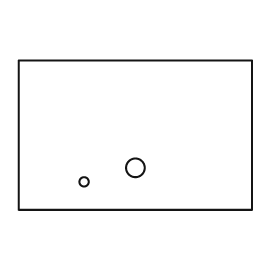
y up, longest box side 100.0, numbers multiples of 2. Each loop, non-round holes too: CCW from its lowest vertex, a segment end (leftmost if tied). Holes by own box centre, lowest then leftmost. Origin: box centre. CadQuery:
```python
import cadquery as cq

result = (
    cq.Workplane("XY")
    .moveTo(-50.0, -32.0)
    .lineTo(50.0, -32.0)
    .lineTo(50.0, 32.0)
    .lineTo(-50.0, 32.0)
    .close()
    .moveTo(-22.0, -20.0)
    .circle(2.0)
    .moveTo(0.0, -14.0)
    .circle(4.0)
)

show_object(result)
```